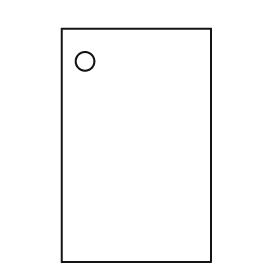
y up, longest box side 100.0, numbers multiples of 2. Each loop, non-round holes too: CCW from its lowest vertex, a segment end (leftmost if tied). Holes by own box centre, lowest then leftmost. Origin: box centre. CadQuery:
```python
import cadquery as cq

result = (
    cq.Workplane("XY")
    .moveTo(-32.0, -50.0)
    .lineTo(32.0, -50.0)
    .lineTo(32.0, 50.0)
    .lineTo(-32.0, 50.0)
    .close()
    .moveTo(-22.0, 36.0)
    .circle(4.0)
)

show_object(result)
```